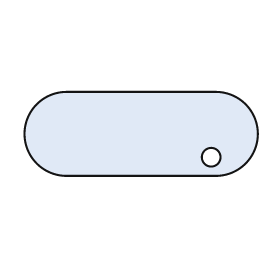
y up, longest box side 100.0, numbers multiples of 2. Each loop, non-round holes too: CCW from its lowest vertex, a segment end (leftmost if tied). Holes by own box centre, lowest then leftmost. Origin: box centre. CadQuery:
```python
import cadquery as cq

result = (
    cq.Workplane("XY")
    .moveTo(-32.0, -18.0)
    .lineTo(32.0, -18.0)
    .threePointArc((50.0, 0.0), (32.0, 18.0))
    .lineTo(-32.0, 18.0)
    .threePointArc((-50.0, 0.0), (-32.0, -18.0))
    .close()
    .moveTo(30.0, -10.0)
    .circle(4.0)
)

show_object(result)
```